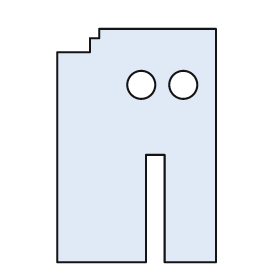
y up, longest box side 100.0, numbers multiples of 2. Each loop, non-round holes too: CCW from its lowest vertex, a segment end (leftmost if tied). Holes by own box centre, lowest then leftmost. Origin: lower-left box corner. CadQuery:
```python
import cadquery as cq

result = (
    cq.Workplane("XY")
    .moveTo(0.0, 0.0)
    .lineTo(38.0, 0.0)
    .lineTo(38.0, 46.0)
    .lineTo(46.0, 46.0)
    .lineTo(46.0, 0.0)
    .lineTo(68.0, 0.0)
    .lineTo(68.0, 100.0)
    .lineTo(18.0, 100.0)
    .lineTo(18.0, 96.0)
    .lineTo(14.0, 96.0)
    .lineTo(14.0, 90.0)
    .lineTo(0.0, 90.0)
    .close()
    .moveTo(36.0, 76.0)
    .circle(6.0)
    .moveTo(54.0, 76.0)
    .circle(6.0)
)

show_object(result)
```